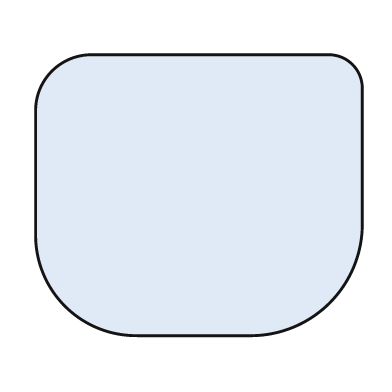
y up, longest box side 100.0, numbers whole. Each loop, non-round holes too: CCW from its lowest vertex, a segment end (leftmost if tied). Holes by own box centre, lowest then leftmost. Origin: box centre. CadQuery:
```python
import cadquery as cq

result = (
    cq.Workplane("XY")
    .moveTo(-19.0, -43.0)
    .lineTo(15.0, -43.0)
    .threePointArc((40.0, -33.0), (50.0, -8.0))
    .lineTo(50.0, 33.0)
    .threePointArc((47.0, 40.0), (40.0, 43.0))
    .lineTo(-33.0, 43.0)
    .threePointArc((-45.0, 38.0), (-50.0, 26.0))
    .lineTo(-50.0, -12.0)
    .threePointArc((-41.0, -34.0), (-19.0, -43.0))
    .close()
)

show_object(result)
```